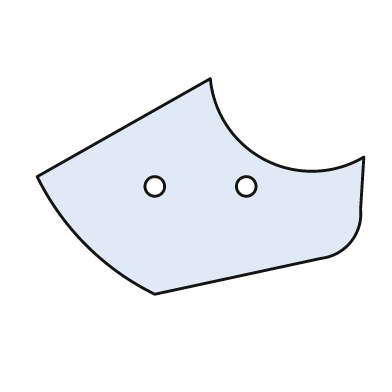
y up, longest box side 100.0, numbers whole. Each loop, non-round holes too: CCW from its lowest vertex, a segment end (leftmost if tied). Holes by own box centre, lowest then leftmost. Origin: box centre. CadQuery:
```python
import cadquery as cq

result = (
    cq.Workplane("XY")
    .moveTo(-14.0, -33.0)
    .lineTo(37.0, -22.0)
    .threePointArc((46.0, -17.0), (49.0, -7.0))
    .lineTo(50.0, 9.0)
    .threePointArc((20.0, 8.0), (3.0, 33.0))
    .lineTo(-50.0, 3.0)
    .threePointArc((-35.0, -18.0), (-14.0, -33.0))
    .close()
    .moveTo(-14.0, 0.0)
    .circle(3.0)
    .moveTo(14.0, 0.0)
    .circle(3.0)
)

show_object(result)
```